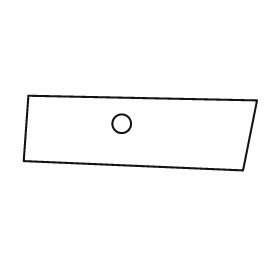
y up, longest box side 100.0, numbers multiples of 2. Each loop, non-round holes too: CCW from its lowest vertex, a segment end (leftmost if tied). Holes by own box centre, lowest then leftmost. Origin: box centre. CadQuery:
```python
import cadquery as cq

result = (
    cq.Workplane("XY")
    .moveTo(44.0, -16.0)
    .lineTo(50.0, 14.0)
    .lineTo(-48.0, 16.0)
    .lineTo(-50.0, -12.0)
    .close()
    .moveTo(-8.0, 4.0)
    .circle(4.0)
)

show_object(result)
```